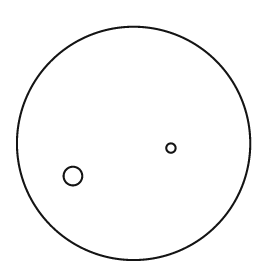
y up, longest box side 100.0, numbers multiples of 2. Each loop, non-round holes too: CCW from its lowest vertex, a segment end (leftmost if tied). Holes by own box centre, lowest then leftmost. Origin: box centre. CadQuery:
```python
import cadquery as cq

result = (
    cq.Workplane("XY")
    .moveTo(0.0, 0.0)
    .circle(50.0)
    .moveTo(-26.0, -14.0)
    .circle(4.0)
    .moveTo(16.0, -2.0)
    .circle(2.0)
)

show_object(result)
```